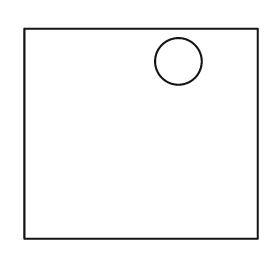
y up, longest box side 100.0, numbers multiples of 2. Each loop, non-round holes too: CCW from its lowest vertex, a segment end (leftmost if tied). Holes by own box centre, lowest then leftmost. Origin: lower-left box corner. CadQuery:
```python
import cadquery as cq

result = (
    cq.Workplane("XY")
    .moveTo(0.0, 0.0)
    .lineTo(100.0, 0.0)
    .lineTo(100.0, 90.0)
    .lineTo(0.0, 90.0)
    .close()
    .moveTo(66.0, 76.0)
    .circle(10.0)
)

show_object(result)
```